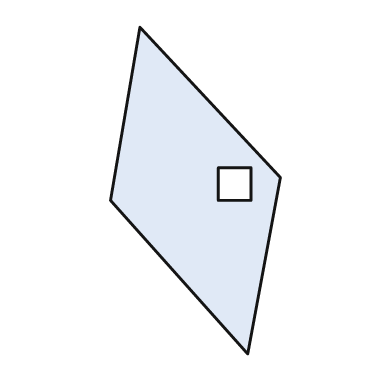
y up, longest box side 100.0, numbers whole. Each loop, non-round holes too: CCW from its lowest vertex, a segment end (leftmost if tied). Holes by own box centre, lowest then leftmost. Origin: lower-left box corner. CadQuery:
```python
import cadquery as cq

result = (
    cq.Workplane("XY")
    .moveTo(42.0, 0.0)
    .lineTo(52.0, 54.0)
    .lineTo(9.0, 100.0)
    .lineTo(0.0, 47.0)
    .close()
    .moveTo(33.0, 47.0)
    .lineTo(43.0, 47.0)
    .lineTo(43.0, 57.0)
    .lineTo(33.0, 57.0)
    .close()
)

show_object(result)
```